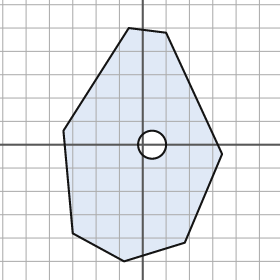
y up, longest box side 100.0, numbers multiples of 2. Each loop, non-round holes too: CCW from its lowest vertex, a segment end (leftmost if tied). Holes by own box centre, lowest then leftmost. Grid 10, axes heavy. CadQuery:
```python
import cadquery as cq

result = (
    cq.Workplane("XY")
    .moveTo(-8.0, -50.0)
    .lineTo(18.0, -42.0)
    .lineTo(34.0, -4.0)
    .lineTo(10.0, 48.0)
    .lineTo(-6.0, 50.0)
    .lineTo(-34.0, 6.0)
    .lineTo(-30.0, -38.0)
    .close()
    .moveTo(4.0, 0.0)
    .circle(6.0)
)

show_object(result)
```